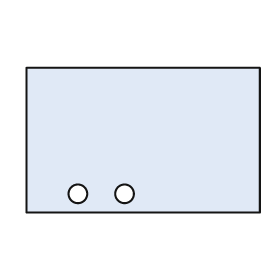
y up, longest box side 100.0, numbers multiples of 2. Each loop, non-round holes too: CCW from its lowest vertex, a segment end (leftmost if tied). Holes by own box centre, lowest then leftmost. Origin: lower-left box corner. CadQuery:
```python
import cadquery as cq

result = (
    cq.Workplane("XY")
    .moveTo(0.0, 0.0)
    .lineTo(100.0, 0.0)
    .lineTo(100.0, 62.0)
    .lineTo(0.0, 62.0)
    .close()
    .moveTo(22.0, 8.0)
    .circle(4.0)
    .moveTo(42.0, 8.0)
    .circle(4.0)
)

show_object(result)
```